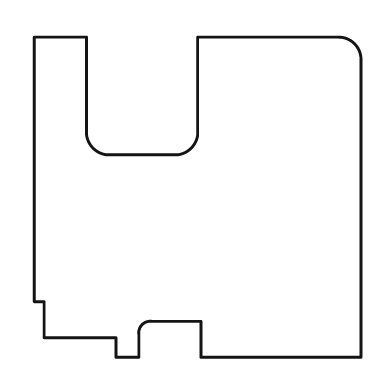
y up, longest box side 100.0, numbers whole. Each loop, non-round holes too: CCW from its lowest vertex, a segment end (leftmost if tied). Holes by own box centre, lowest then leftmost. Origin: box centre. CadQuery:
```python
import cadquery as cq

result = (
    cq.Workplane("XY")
    .moveTo(-25.0, -49.0)
    .lineTo(-18.0, -49.0)
    .lineTo(-18.0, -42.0)
    .threePointArc((-17.0, -39.0), (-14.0, -38.0))
    .lineTo(1.0, -38.0)
    .lineTo(1.0, -49.0)
    .lineTo(50.0, -49.0)
    .lineTo(50.0, 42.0)
    .threePointArc((48.0, 47.0), (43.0, 49.0))
    .lineTo(0.0, 49.0)
    .lineTo(0.0, 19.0)
    .threePointArc((-2.0, 15.0), (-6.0, 13.0))
    .lineTo(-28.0, 13.0)
    .threePointArc((-32.0, 15.0), (-34.0, 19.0))
    .lineTo(-34.0, 49.0)
    .lineTo(-50.0, 49.0)
    .lineTo(-50.0, -32.0)
    .lineTo(-47.0, -32.0)
    .lineTo(-47.0, -43.0)
    .lineTo(-25.0, -43.0)
    .close()
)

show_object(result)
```